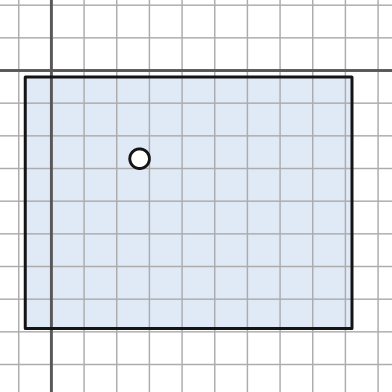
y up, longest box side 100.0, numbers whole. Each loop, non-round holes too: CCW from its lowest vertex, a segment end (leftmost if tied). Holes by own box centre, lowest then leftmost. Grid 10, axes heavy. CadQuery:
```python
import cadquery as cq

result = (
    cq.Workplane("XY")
    .moveTo(-8.0, -79.0)
    .lineTo(92.0, -79.0)
    .lineTo(92.0, -2.0)
    .lineTo(-8.0, -2.0)
    .close()
    .moveTo(27.0, -27.0)
    .circle(3.0)
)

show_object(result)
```